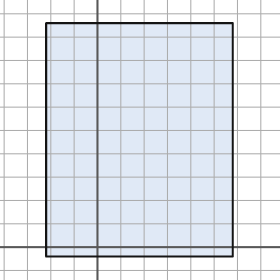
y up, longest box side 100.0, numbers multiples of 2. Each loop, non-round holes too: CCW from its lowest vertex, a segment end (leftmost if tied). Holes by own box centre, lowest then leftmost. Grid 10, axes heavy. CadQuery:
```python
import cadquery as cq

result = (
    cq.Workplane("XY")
    .moveTo(-22.0, -4.0)
    .lineTo(58.0, -4.0)
    .lineTo(58.0, 96.0)
    .lineTo(-22.0, 96.0)
    .close()
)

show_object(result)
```